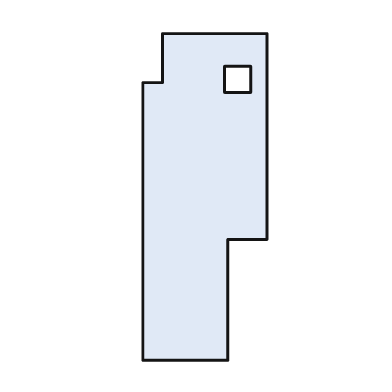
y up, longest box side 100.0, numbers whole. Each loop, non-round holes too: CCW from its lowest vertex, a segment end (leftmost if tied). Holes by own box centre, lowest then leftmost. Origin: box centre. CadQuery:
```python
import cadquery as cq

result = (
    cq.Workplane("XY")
    .moveTo(-19.0, -50.0)
    .lineTo(7.0, -50.0)
    .lineTo(7.0, -13.0)
    .lineTo(19.0, -13.0)
    .lineTo(19.0, 50.0)
    .lineTo(-13.0, 50.0)
    .lineTo(-13.0, 35.0)
    .lineTo(-19.0, 35.0)
    .close()
    .moveTo(6.0, 32.0)
    .lineTo(14.0, 32.0)
    .lineTo(14.0, 40.0)
    .lineTo(6.0, 40.0)
    .close()
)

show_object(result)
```